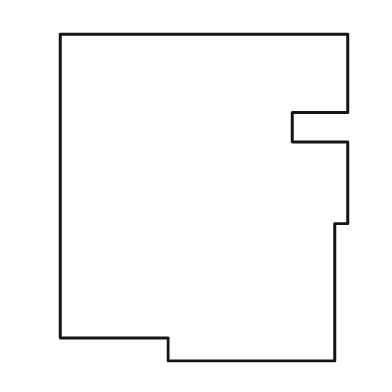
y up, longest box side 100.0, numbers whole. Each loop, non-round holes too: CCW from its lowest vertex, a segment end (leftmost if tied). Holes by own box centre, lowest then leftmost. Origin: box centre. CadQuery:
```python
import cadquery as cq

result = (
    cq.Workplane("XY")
    .moveTo(-11.0, -50.0)
    .lineTo(40.0, -50.0)
    .lineTo(40.0, -8.0)
    .lineTo(44.0, -8.0)
    .lineTo(44.0, 17.0)
    .lineTo(27.0, 17.0)
    .lineTo(27.0, 26.0)
    .lineTo(44.0, 26.0)
    .lineTo(44.0, 50.0)
    .lineTo(-44.0, 50.0)
    .lineTo(-44.0, -43.0)
    .lineTo(-11.0, -43.0)
    .close()
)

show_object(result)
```